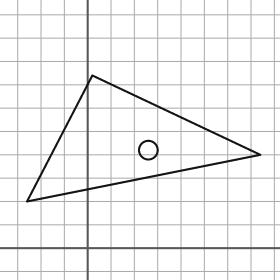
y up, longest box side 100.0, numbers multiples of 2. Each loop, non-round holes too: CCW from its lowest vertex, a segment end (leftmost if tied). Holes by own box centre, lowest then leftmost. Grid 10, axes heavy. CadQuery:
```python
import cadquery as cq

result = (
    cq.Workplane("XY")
    .moveTo(-26.0, 20.0)
    .lineTo(74.0, 40.0)
    .lineTo(2.0, 74.0)
    .close()
    .moveTo(26.0, 42.0)
    .circle(4.0)
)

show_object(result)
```